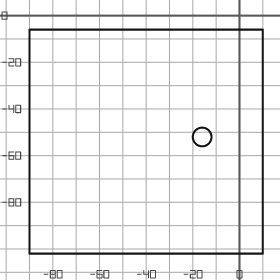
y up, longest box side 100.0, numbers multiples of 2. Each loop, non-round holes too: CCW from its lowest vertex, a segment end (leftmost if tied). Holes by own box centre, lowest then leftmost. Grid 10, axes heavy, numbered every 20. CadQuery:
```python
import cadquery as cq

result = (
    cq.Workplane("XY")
    .moveTo(-90.0, -102.0)
    .lineTo(10.0, -102.0)
    .lineTo(10.0, -6.0)
    .lineTo(-90.0, -6.0)
    .close()
    .moveTo(-16.0, -52.0)
    .circle(4.0)
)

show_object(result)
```